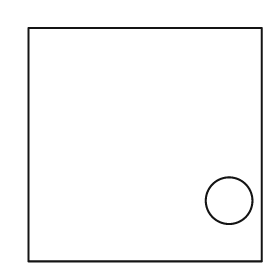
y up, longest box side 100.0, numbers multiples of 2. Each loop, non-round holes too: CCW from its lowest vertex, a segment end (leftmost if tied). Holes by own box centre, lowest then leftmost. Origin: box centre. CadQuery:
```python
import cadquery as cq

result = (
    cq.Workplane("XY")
    .moveTo(-50.0, -50.0)
    .lineTo(50.0, -50.0)
    .lineTo(50.0, 50.0)
    .lineTo(-50.0, 50.0)
    .close()
    .moveTo(36.0, -24.0)
    .circle(10.0)
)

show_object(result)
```